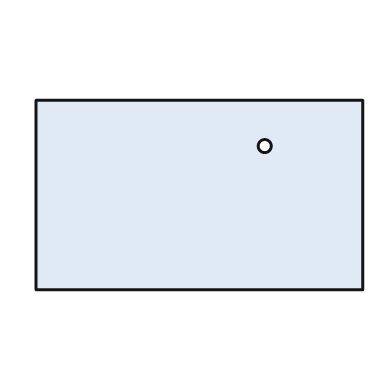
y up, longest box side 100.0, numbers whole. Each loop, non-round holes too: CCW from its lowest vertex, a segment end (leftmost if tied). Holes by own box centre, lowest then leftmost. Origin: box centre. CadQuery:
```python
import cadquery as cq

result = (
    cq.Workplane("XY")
    .moveTo(-50.0, -29.0)
    .lineTo(50.0, -29.0)
    .lineTo(50.0, 29.0)
    .lineTo(-50.0, 29.0)
    .close()
    .moveTo(20.0, 15.0)
    .circle(2.0)
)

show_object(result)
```